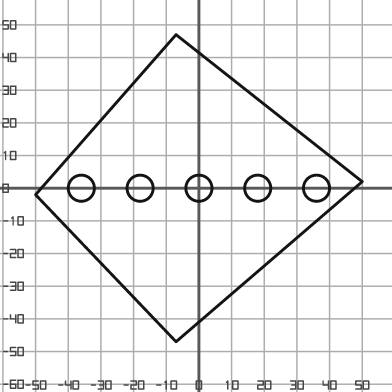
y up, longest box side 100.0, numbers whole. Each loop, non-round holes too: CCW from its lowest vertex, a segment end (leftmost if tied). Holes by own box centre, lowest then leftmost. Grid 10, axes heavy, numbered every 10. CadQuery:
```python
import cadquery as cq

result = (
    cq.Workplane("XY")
    .moveTo(-7.0, -47.0)
    .lineTo(50.0, 2.0)
    .lineTo(-7.0, 47.0)
    .lineTo(-50.0, -2.0)
    .close()
    .moveTo(-36.0, 0.0)
    .circle(4.0)
    .moveTo(-18.0, 0.0)
    .circle(4.0)
    .moveTo(0.0, 0.0)
    .circle(4.0)
    .moveTo(18.0, 0.0)
    .circle(4.0)
    .moveTo(36.0, 0.0)
    .circle(4.0)
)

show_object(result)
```